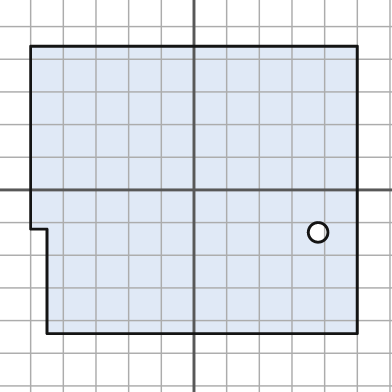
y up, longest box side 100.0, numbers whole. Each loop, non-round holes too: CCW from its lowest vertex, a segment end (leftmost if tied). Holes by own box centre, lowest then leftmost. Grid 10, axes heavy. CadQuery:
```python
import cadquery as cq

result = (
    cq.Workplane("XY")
    .moveTo(-45.0, -44.0)
    .lineTo(50.0, -44.0)
    .lineTo(50.0, 44.0)
    .lineTo(-50.0, 44.0)
    .lineTo(-50.0, -12.0)
    .lineTo(-45.0, -12.0)
    .close()
    .moveTo(38.0, -13.0)
    .circle(3.0)
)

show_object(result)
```